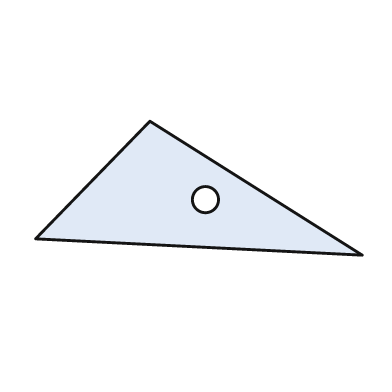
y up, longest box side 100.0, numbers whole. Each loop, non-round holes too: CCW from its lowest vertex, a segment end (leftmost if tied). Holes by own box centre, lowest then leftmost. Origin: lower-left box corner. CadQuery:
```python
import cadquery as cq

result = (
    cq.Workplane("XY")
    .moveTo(100.0, 0.0)
    .lineTo(35.0, 41.0)
    .lineTo(0.0, 5.0)
    .close()
    .moveTo(52.0, 17.0)
    .circle(4.0)
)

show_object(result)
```